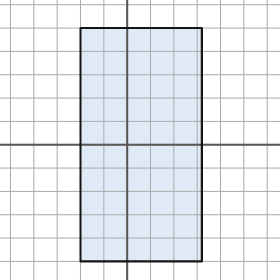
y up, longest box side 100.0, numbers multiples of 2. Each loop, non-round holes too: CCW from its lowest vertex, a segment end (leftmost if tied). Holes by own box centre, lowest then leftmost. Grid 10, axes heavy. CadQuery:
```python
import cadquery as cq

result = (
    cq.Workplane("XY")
    .moveTo(-20.0, -50.0)
    .lineTo(32.0, -50.0)
    .lineTo(32.0, 50.0)
    .lineTo(-20.0, 50.0)
    .close()
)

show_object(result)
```